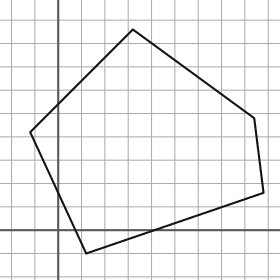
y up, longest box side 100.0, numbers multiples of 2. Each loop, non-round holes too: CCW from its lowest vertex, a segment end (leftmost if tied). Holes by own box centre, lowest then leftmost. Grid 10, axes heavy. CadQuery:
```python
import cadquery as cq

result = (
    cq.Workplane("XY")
    .moveTo(12.0, -10.0)
    .lineTo(88.0, 16.0)
    .lineTo(84.0, 48.0)
    .lineTo(32.0, 86.0)
    .lineTo(-12.0, 42.0)
    .close()
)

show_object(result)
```